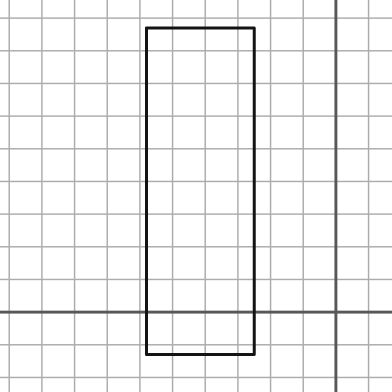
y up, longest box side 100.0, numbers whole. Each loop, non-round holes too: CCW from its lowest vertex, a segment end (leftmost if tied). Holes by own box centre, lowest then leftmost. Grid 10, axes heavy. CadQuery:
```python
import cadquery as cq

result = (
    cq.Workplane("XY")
    .moveTo(-58.0, -13.0)
    .lineTo(-25.0, -13.0)
    .lineTo(-25.0, 87.0)
    .lineTo(-58.0, 87.0)
    .close()
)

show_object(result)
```